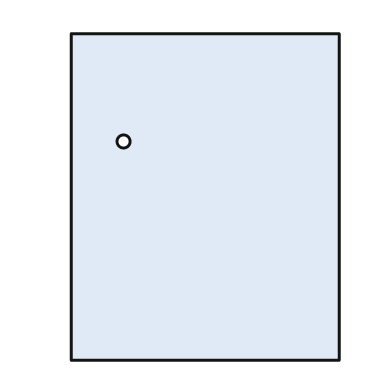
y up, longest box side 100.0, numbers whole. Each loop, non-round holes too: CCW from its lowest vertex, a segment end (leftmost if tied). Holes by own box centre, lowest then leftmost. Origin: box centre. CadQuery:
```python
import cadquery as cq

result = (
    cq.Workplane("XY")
    .moveTo(-41.0, -50.0)
    .lineTo(41.0, -50.0)
    .lineTo(41.0, 50.0)
    .lineTo(-41.0, 50.0)
    .close()
    .moveTo(-25.0, 17.0)
    .circle(2.0)
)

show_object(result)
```